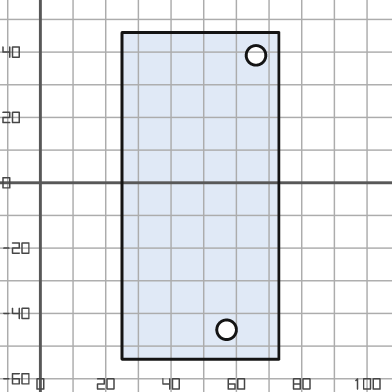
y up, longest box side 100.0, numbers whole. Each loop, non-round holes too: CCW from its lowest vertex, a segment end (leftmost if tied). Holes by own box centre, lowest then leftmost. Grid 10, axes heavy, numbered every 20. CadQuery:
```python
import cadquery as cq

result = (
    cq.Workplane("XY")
    .moveTo(25.0, -54.0)
    .lineTo(73.0, -54.0)
    .lineTo(73.0, 46.0)
    .lineTo(25.0, 46.0)
    .close()
    .moveTo(57.0, -45.0)
    .circle(3.0)
    .moveTo(66.0, 39.0)
    .circle(3.0)
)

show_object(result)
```